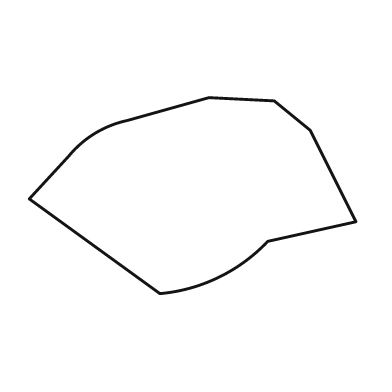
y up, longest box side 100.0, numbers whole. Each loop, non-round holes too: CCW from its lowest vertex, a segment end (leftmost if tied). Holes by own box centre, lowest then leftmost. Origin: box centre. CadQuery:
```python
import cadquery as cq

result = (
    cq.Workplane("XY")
    .moveTo(-10.0, -30.0)
    .threePointArc((8.0, -25.0), (23.0, -14.0))
    .lineTo(50.0, -8.0)
    .lineTo(36.0, 20.0)
    .lineTo(25.0, 29.0)
    .lineTo(5.0, 30.0)
    .lineTo(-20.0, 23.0)
    .threePointArc((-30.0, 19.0), (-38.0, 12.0))
    .lineTo(-50.0, -1.0)
    .close()
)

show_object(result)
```